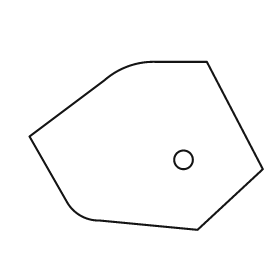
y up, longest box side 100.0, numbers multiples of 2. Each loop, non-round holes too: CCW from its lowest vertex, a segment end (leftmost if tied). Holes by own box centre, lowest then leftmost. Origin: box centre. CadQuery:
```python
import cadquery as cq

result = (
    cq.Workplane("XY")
    .moveTo(22.0, -36.0)
    .lineTo(50.0, -10.0)
    .lineTo(26.0, 36.0)
    .lineTo(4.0, 36.0)
    .threePointArc((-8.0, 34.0), (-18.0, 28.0))
    .lineTo(-50.0, 4.0)
    .lineTo(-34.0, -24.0)
    .threePointArc((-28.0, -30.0), (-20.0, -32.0))
    .close()
    .moveTo(16.0, -6.0)
    .circle(4.0)
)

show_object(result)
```